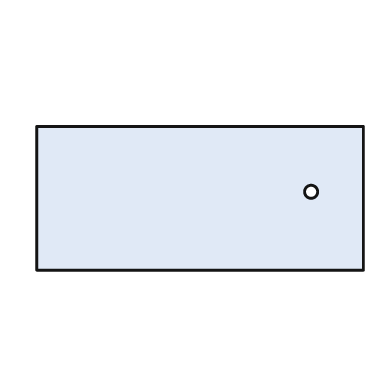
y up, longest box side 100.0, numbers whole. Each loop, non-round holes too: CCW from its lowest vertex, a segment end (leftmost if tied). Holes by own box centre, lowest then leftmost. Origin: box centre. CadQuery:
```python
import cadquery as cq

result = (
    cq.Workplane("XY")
    .moveTo(-50.0, -22.0)
    .lineTo(50.0, -22.0)
    .lineTo(50.0, 22.0)
    .lineTo(-50.0, 22.0)
    .close()
    .moveTo(34.0, 2.0)
    .circle(2.0)
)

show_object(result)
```